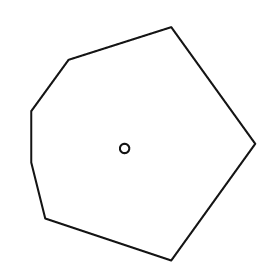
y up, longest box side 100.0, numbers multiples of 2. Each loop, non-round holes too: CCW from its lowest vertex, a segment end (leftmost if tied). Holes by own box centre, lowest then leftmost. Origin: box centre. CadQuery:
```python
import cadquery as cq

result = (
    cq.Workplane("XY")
    .moveTo(12.0, -50.0)
    .lineTo(48.0, 0.0)
    .lineTo(12.0, 50.0)
    .lineTo(-32.0, 36.0)
    .lineTo(-48.0, 14.0)
    .lineTo(-48.0, -8.0)
    .lineTo(-42.0, -32.0)
    .close()
    .moveTo(-8.0, -2.0)
    .circle(2.0)
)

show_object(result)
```